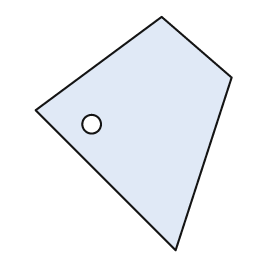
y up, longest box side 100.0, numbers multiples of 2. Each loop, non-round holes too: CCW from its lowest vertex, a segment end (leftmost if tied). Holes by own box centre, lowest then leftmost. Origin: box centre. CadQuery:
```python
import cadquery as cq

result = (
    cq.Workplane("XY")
    .moveTo(18.0, -50.0)
    .lineTo(42.0, 24.0)
    .lineTo(12.0, 50.0)
    .lineTo(-42.0, 10.0)
    .close()
    .moveTo(-18.0, 4.0)
    .circle(4.0)
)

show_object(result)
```